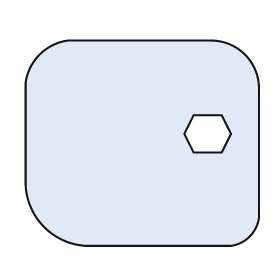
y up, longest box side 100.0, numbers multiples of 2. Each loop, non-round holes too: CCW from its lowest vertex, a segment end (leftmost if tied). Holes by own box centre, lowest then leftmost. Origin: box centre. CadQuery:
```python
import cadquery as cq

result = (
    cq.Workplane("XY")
    .moveTo(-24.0, -44.0)
    .lineTo(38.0, -44.0)
    .threePointArc((46.0, -40.0), (50.0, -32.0))
    .lineTo(50.0, 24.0)
    .threePointArc((44.0, 38.0), (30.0, 44.0))
    .lineTo(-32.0, 44.0)
    .threePointArc((-44.0, 38.0), (-50.0, 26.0))
    .lineTo(-50.0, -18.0)
    .threePointArc((-42.0, -36.0), (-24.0, -44.0))
    .close()
    .moveTo(22.0, -4.0)
    .lineTo(34.0, -4.0)
    .lineTo(38.0, 4.0)
    .lineTo(34.0, 12.0)
    .lineTo(22.0, 12.0)
    .lineTo(18.0, 4.0)
    .close()
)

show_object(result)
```